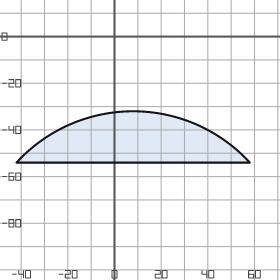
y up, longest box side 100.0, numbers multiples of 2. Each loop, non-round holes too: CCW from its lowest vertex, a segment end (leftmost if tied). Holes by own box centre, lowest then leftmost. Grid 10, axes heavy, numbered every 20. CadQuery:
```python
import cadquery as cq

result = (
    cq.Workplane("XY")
    .moveTo(-42.0, -54.0)
    .lineTo(58.0, -54.0)
    .threePointArc((8.0, -32.0), (-42.0, -54.0))
    .close()
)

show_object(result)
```